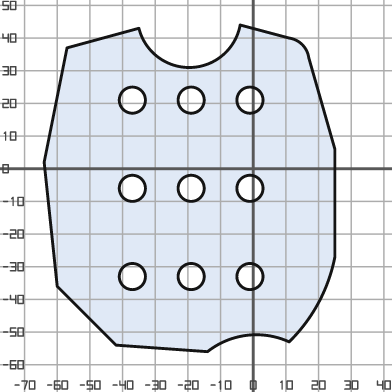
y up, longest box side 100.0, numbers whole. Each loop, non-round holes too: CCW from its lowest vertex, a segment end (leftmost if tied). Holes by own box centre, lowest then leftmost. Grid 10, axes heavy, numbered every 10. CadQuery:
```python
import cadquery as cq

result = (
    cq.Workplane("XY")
    .moveTo(-14.0, -56.0)
    .threePointArc((-2.0, -51.0), (11.0, -53.0))
    .threePointArc((20.0, -41.0), (25.0, -27.0))
    .lineTo(25.0, 6.0)
    .lineTo(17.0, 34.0)
    .threePointArc((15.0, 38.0), (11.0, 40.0))
    .lineTo(-4.0, 44.0)
    .threePointArc((-19.0, 31.0), (-35.0, 43.0))
    .lineTo(-57.0, 37.0)
    .lineTo(-64.0, 2.0)
    .lineTo(-60.0, -36.0)
    .lineTo(-42.0, -54.0)
    .close()
    .moveTo(-37.0, -33.0)
    .circle(4.0)
    .moveTo(-19.0, -33.0)
    .circle(4.0)
    .moveTo(-1.0, -33.0)
    .circle(4.0)
    .moveTo(-37.0, -6.0)
    .circle(4.0)
    .moveTo(-19.0, -6.0)
    .circle(4.0)
    .moveTo(-1.0, -6.0)
    .circle(4.0)
    .moveTo(-37.0, 21.0)
    .circle(4.0)
    .moveTo(-19.0, 21.0)
    .circle(4.0)
    .moveTo(-1.0, 21.0)
    .circle(4.0)
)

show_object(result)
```